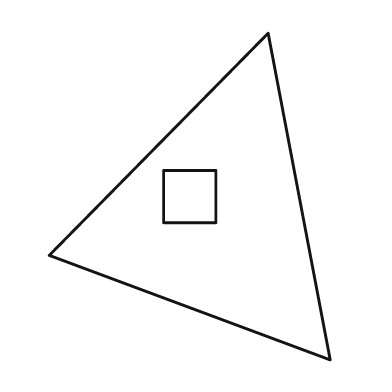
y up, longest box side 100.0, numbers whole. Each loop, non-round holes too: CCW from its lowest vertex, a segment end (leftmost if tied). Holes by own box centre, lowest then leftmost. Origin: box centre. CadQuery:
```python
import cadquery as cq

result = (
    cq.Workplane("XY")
    .moveTo(43.0, -50.0)
    .lineTo(24.0, 50.0)
    .lineTo(-43.0, -18.0)
    .close()
    .moveTo(-8.0, -8.0)
    .lineTo(8.0, -8.0)
    .lineTo(8.0, 8.0)
    .lineTo(-8.0, 8.0)
    .close()
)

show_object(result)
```